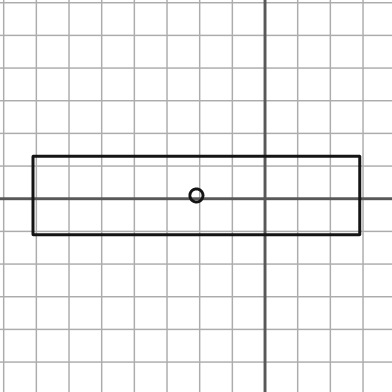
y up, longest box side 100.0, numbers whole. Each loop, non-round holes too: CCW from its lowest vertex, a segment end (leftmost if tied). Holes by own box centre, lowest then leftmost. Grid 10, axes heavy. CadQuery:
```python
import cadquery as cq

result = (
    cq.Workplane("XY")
    .moveTo(-71.0, -11.0)
    .lineTo(29.0, -11.0)
    .lineTo(29.0, 13.0)
    .lineTo(-71.0, 13.0)
    .close()
    .moveTo(-21.0, 1.0)
    .circle(2.0)
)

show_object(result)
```